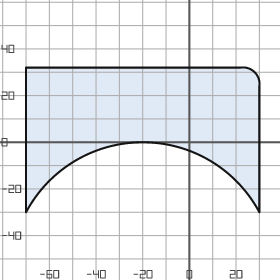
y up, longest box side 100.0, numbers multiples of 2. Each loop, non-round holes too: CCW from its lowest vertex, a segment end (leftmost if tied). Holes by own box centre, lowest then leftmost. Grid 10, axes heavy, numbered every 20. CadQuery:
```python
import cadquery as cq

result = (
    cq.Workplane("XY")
    .moveTo(-70.0, -30.0)
    .threePointArc((-20.0, 0.0), (30.0, -30.0))
    .lineTo(30.0, 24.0)
    .threePointArc((28.0, 30.0), (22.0, 32.0))
    .lineTo(-70.0, 32.0)
    .close()
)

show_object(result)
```